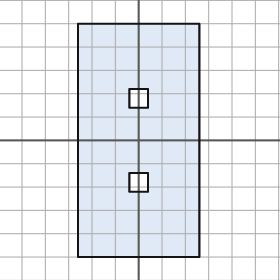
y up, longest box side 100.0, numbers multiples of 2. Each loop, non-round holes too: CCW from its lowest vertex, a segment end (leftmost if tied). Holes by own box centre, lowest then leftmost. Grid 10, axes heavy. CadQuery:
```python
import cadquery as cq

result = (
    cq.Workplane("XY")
    .moveTo(-26.0, -50.0)
    .lineTo(26.0, -50.0)
    .lineTo(26.0, 50.0)
    .lineTo(-26.0, 50.0)
    .close()
    .moveTo(-4.0, -22.0)
    .lineTo(4.0, -22.0)
    .lineTo(4.0, -14.0)
    .lineTo(-4.0, -14.0)
    .close()
    .moveTo(-4.0, 14.0)
    .lineTo(4.0, 14.0)
    .lineTo(4.0, 22.0)
    .lineTo(-4.0, 22.0)
    .close()
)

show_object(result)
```